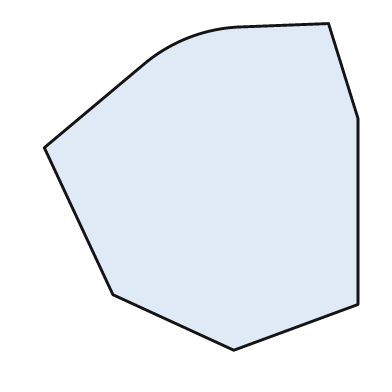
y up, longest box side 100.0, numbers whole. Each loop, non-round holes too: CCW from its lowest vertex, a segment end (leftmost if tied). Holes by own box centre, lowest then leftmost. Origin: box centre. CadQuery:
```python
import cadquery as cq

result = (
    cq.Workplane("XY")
    .moveTo(10.0, -50.0)
    .lineTo(48.0, -36.0)
    .lineTo(48.0, 21.0)
    .lineTo(39.0, 50.0)
    .lineTo(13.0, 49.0)
    .threePointArc((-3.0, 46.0), (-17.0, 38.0))
    .lineTo(-48.0, 12.0)
    .lineTo(-27.0, -33.0)
    .close()
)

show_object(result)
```